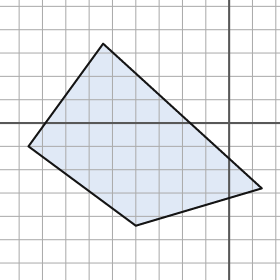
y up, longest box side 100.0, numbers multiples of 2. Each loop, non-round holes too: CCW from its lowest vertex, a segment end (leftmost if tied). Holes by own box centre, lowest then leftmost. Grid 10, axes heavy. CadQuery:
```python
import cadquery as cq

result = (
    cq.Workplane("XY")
    .moveTo(-40.0, -44.0)
    .lineTo(14.0, -28.0)
    .lineTo(-54.0, 34.0)
    .lineTo(-86.0, -10.0)
    .close()
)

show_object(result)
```